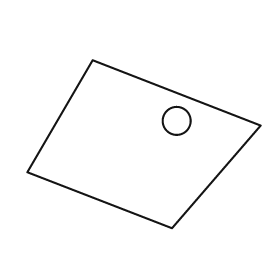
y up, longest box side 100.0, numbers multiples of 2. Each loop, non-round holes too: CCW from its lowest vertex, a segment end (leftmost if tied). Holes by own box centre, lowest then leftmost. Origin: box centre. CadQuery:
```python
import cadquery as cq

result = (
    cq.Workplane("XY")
    .moveTo(12.0, -36.0)
    .lineTo(50.0, 8.0)
    .lineTo(-22.0, 36.0)
    .lineTo(-50.0, -12.0)
    .close()
    .moveTo(14.0, 10.0)
    .circle(6.0)
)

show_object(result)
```